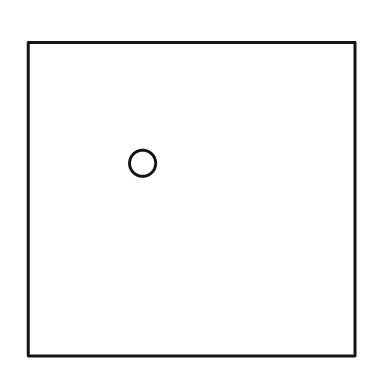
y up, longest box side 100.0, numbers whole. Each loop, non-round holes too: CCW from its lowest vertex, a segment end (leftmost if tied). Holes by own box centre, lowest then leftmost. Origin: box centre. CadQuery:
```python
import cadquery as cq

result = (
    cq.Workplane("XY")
    .moveTo(-50.0, -48.0)
    .lineTo(50.0, -48.0)
    .lineTo(50.0, 48.0)
    .lineTo(-50.0, 48.0)
    .close()
    .moveTo(-15.0, 11.0)
    .circle(4.0)
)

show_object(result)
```